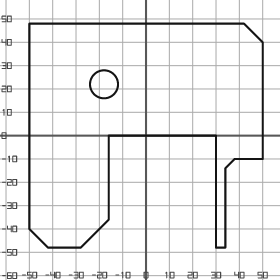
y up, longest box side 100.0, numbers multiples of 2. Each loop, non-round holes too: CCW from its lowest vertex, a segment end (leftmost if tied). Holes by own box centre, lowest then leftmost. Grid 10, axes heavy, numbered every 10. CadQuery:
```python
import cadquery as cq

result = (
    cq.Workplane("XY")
    .moveTo(-42.0, -48.0)
    .lineTo(-28.0, -48.0)
    .lineTo(-16.0, -36.0)
    .lineTo(-16.0, 0.0)
    .lineTo(30.0, 0.0)
    .lineTo(30.0, -48.0)
    .lineTo(34.0, -48.0)
    .lineTo(34.0, -14.0)
    .lineTo(38.0, -10.0)
    .lineTo(50.0, -10.0)
    .lineTo(50.0, 40.0)
    .lineTo(42.0, 48.0)
    .lineTo(-50.0, 48.0)
    .lineTo(-50.0, -40.0)
    .close()
    .moveTo(-18.0, 22.0)
    .circle(6.0)
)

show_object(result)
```